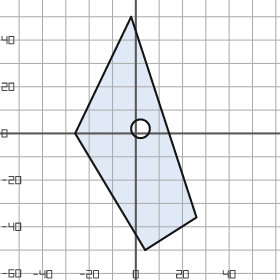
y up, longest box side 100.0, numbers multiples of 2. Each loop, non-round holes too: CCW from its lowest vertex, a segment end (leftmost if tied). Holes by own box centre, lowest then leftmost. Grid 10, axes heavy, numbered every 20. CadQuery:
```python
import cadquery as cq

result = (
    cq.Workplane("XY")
    .moveTo(4.0, -50.0)
    .lineTo(26.0, -36.0)
    .lineTo(-2.0, 50.0)
    .lineTo(-26.0, 0.0)
    .close()
    .moveTo(2.0, 2.0)
    .circle(4.0)
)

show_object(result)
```